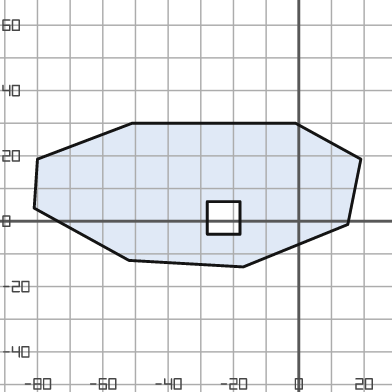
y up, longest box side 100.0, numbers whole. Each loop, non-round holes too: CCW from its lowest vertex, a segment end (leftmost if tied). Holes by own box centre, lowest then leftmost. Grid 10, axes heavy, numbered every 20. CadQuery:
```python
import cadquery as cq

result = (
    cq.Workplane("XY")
    .moveTo(-17.0, -14.0)
    .lineTo(15.0, -1.0)
    .lineTo(19.0, 19.0)
    .lineTo(-1.0, 30.0)
    .lineTo(-51.0, 30.0)
    .lineTo(-80.0, 19.0)
    .lineTo(-81.0, 4.0)
    .lineTo(-52.0, -12.0)
    .close()
    .moveTo(-28.0, -4.0)
    .lineTo(-18.0, -4.0)
    .lineTo(-18.0, 6.0)
    .lineTo(-28.0, 6.0)
    .close()
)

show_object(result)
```